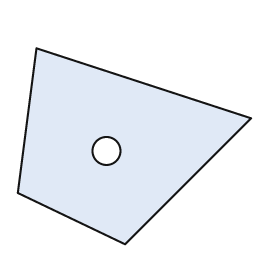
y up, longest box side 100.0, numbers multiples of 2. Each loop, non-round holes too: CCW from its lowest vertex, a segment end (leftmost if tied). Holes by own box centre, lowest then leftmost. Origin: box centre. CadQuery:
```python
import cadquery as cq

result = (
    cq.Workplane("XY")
    .moveTo(-4.0, -42.0)
    .lineTo(50.0, 12.0)
    .lineTo(-42.0, 42.0)
    .lineTo(-50.0, -20.0)
    .close()
    .moveTo(-12.0, -2.0)
    .circle(6.0)
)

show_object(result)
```